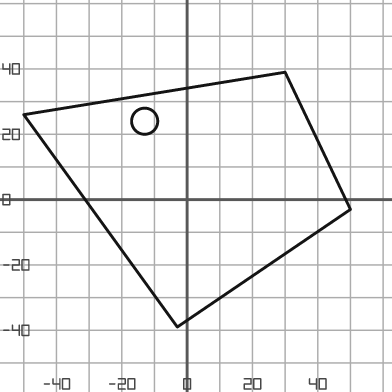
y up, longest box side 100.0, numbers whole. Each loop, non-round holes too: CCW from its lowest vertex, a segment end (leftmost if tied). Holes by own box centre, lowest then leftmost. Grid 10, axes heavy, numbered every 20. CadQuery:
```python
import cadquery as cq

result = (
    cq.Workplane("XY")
    .moveTo(-3.0, -39.0)
    .lineTo(50.0, -3.0)
    .lineTo(30.0, 39.0)
    .lineTo(-50.0, 26.0)
    .close()
    .moveTo(-13.0, 24.0)
    .circle(4.0)
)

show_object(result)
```